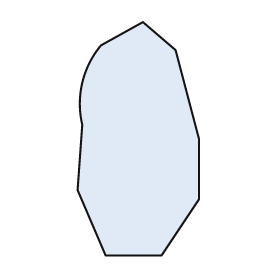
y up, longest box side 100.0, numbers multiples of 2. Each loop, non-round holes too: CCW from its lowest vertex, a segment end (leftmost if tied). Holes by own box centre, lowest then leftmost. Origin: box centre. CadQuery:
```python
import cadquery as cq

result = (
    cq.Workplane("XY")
    .moveTo(-14.0, -50.0)
    .lineTo(10.0, -50.0)
    .lineTo(26.0, -26.0)
    .lineTo(26.0, 0.0)
    .lineTo(16.0, 38.0)
    .lineTo(2.0, 50.0)
    .lineTo(-16.0, 40.0)
    .threePointArc((-24.0, 24.0), (-24.0, 6.0))
    .lineTo(-26.0, -22.0)
    .close()
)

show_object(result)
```